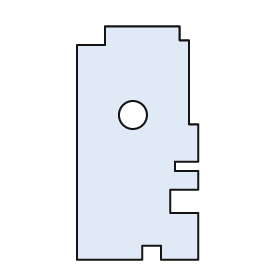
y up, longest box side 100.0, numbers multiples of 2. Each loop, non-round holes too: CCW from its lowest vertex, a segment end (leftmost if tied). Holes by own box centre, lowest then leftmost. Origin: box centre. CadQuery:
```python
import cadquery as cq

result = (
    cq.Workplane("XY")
    .moveTo(-26.0, -50.0)
    .lineTo(2.0, -50.0)
    .lineTo(2.0, -44.0)
    .lineTo(10.0, -44.0)
    .lineTo(10.0, -50.0)
    .lineTo(26.0, -50.0)
    .lineTo(26.0, -30.0)
    .lineTo(14.0, -30.0)
    .lineTo(14.0, -20.0)
    .lineTo(26.0, -20.0)
    .lineTo(26.0, -12.0)
    .lineTo(16.0, -12.0)
    .lineTo(16.0, -8.0)
    .lineTo(26.0, -8.0)
    .lineTo(26.0, 8.0)
    .lineTo(22.0, 8.0)
    .lineTo(22.0, 44.0)
    .lineTo(18.0, 44.0)
    .lineTo(18.0, 50.0)
    .lineTo(-14.0, 50.0)
    .lineTo(-14.0, 42.0)
    .lineTo(-26.0, 42.0)
    .close()
    .moveTo(-2.0, 12.0)
    .circle(6.0)
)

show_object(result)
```